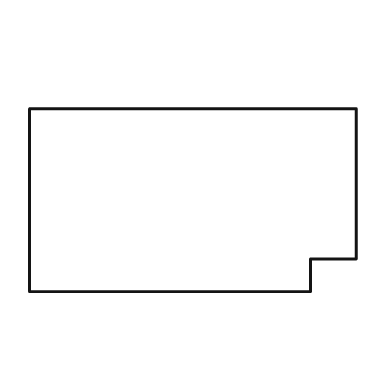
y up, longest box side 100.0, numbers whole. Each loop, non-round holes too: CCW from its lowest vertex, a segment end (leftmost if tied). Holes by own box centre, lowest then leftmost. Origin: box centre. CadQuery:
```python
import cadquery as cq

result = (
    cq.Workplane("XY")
    .moveTo(-50.0, -28.0)
    .lineTo(36.0, -28.0)
    .lineTo(36.0, -18.0)
    .lineTo(50.0, -18.0)
    .lineTo(50.0, 28.0)
    .lineTo(-50.0, 28.0)
    .close()
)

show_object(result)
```